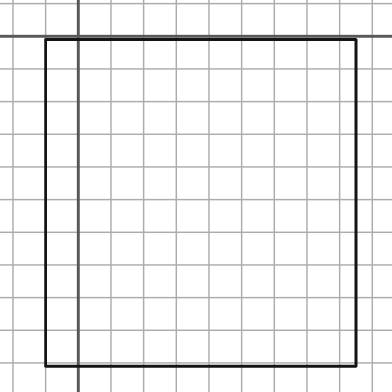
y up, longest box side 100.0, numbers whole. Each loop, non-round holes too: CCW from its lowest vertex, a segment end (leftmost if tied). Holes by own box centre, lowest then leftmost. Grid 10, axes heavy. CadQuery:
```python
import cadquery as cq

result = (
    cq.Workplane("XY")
    .moveTo(-10.0, -101.0)
    .lineTo(85.0, -101.0)
    .lineTo(85.0, -1.0)
    .lineTo(-10.0, -1.0)
    .close()
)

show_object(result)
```